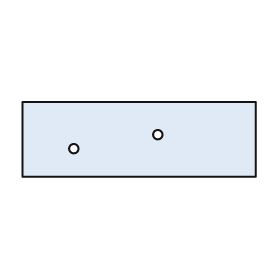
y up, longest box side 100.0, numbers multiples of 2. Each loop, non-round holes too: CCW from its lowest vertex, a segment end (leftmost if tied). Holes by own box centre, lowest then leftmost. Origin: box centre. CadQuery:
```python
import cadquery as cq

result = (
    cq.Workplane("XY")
    .moveTo(-50.0, -16.0)
    .lineTo(50.0, -16.0)
    .lineTo(50.0, 16.0)
    .lineTo(-50.0, 16.0)
    .close()
    .moveTo(-28.0, -4.0)
    .circle(2.0)
    .moveTo(8.0, 2.0)
    .circle(2.0)
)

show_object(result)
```